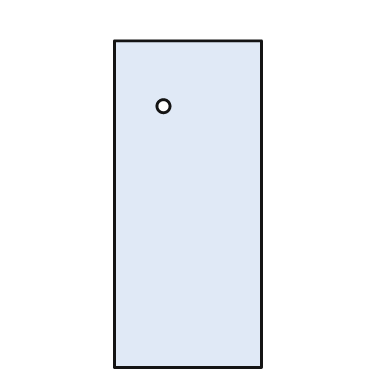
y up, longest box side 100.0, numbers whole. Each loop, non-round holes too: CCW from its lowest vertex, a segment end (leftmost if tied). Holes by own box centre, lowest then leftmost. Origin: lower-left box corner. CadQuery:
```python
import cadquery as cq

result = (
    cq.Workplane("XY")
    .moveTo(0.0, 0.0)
    .lineTo(45.0, 0.0)
    .lineTo(45.0, 100.0)
    .lineTo(0.0, 100.0)
    .close()
    .moveTo(15.0, 80.0)
    .circle(2.0)
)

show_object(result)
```